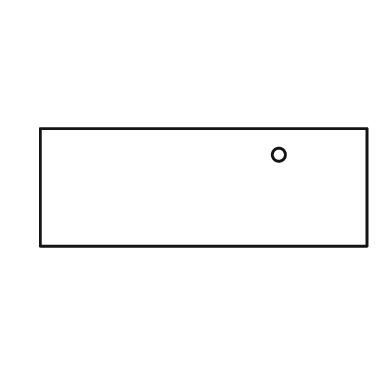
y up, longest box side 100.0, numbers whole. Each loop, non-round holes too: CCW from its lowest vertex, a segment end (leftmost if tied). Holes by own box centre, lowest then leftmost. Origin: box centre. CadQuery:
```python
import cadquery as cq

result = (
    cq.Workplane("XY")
    .moveTo(-50.0, -18.0)
    .lineTo(50.0, -18.0)
    .lineTo(50.0, 18.0)
    .lineTo(-50.0, 18.0)
    .close()
    .moveTo(23.0, 10.0)
    .circle(2.0)
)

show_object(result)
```